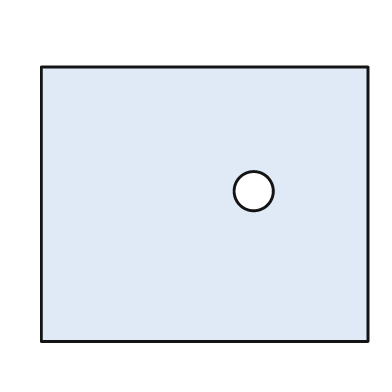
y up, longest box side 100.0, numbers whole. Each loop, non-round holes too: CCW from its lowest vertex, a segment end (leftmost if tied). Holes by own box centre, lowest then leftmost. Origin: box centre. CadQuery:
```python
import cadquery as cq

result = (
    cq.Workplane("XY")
    .moveTo(-50.0, -42.0)
    .lineTo(50.0, -42.0)
    .lineTo(50.0, 42.0)
    .lineTo(-50.0, 42.0)
    .close()
    .moveTo(15.0, 4.0)
    .circle(6.0)
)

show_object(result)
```